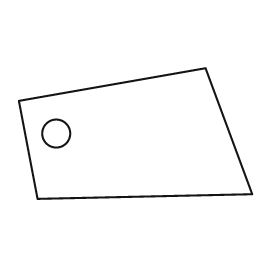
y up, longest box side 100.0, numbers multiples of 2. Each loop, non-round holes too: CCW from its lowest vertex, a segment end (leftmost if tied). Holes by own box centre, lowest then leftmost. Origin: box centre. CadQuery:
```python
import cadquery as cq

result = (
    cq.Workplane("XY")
    .moveTo(-42.0, -28.0)
    .lineTo(50.0, -26.0)
    .lineTo(30.0, 28.0)
    .lineTo(-50.0, 14.0)
    .close()
    .moveTo(-34.0, 0.0)
    .circle(6.0)
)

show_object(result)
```